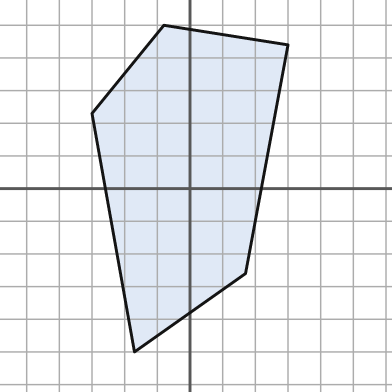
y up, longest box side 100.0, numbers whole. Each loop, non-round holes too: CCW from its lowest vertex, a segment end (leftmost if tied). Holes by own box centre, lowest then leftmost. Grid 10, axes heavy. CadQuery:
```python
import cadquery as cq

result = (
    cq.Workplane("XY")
    .moveTo(-17.0, -50.0)
    .lineTo(17.0, -26.0)
    .lineTo(30.0, 44.0)
    .lineTo(-8.0, 50.0)
    .lineTo(-30.0, 23.0)
    .close()
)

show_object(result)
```